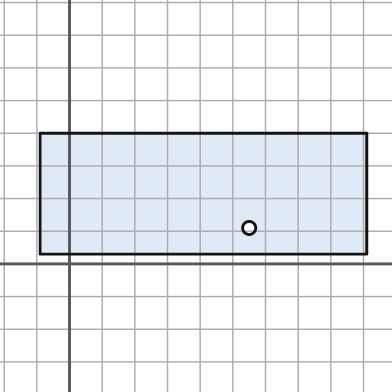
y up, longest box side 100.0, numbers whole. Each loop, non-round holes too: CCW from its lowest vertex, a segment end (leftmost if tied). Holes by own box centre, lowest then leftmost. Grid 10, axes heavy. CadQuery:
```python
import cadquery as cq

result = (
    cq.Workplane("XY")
    .moveTo(-9.0, 3.0)
    .lineTo(91.0, 3.0)
    .lineTo(91.0, 40.0)
    .lineTo(-9.0, 40.0)
    .close()
    .moveTo(55.0, 11.0)
    .circle(2.0)
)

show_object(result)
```